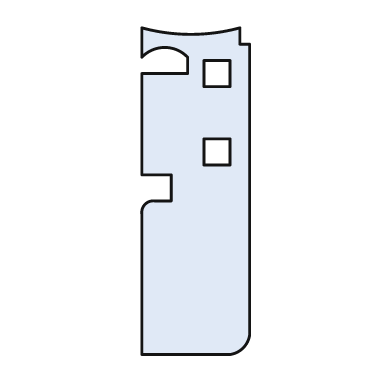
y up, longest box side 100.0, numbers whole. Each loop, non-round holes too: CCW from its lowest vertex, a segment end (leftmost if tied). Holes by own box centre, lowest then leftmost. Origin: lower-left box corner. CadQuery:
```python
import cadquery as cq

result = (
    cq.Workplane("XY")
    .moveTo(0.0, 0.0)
    .lineTo(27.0, 0.0)
    .threePointArc((31.0, 2.0), (33.0, 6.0))
    .lineTo(33.0, 95.0)
    .lineTo(30.0, 95.0)
    .lineTo(30.0, 100.0)
    .threePointArc((15.0, 98.0), (0.0, 100.0))
    .lineTo(0.0, 91.0)
    .threePointArc((7.0, 94.0), (14.0, 91.0))
    .lineTo(14.0, 86.0)
    .lineTo(0.0, 86.0)
    .lineTo(0.0, 55.0)
    .lineTo(9.0, 55.0)
    .lineTo(9.0, 47.0)
    .lineTo(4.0, 47.0)
    .threePointArc((1.0, 46.0), (0.0, 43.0))
    .close()
    .moveTo(19.0, 58.0)
    .lineTo(27.0, 58.0)
    .lineTo(27.0, 66.0)
    .lineTo(19.0, 66.0)
    .close()
    .moveTo(19.0, 82.0)
    .lineTo(27.0, 82.0)
    .lineTo(27.0, 90.0)
    .lineTo(19.0, 90.0)
    .close()
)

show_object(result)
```